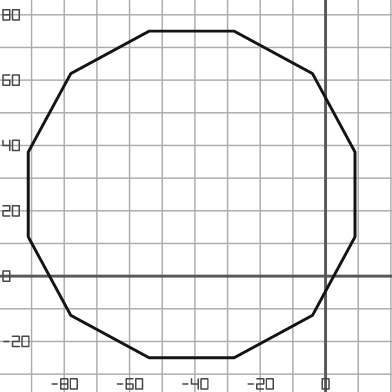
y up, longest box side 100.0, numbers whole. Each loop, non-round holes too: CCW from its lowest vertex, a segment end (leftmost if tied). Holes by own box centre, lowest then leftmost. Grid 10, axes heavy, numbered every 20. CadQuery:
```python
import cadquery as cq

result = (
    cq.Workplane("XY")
    .moveTo(-54.0, -25.0)
    .lineTo(-28.0, -25.0)
    .lineTo(-4.0, -12.0)
    .lineTo(9.0, 12.0)
    .lineTo(9.0, 38.0)
    .lineTo(-4.0, 62.0)
    .lineTo(-28.0, 75.0)
    .lineTo(-54.0, 75.0)
    .lineTo(-78.0, 62.0)
    .lineTo(-91.0, 38.0)
    .lineTo(-91.0, 12.0)
    .lineTo(-78.0, -12.0)
    .close()
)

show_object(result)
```